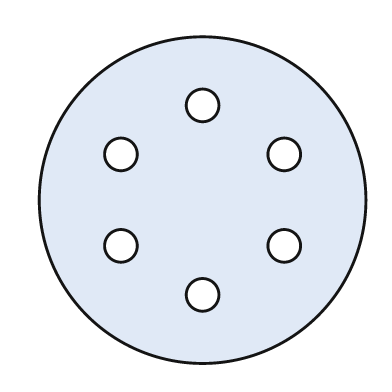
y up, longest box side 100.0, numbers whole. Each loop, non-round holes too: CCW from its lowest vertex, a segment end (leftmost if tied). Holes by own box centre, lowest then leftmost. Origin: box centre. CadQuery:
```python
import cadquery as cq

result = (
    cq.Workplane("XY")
    .moveTo(0.0, 0.0)
    .circle(50.0)
    .moveTo(0.0, -29.0)
    .circle(5.0)
    .moveTo(-25.0, -14.0)
    .circle(5.0)
    .moveTo(25.0, -14.0)
    .circle(5.0)
    .moveTo(-25.0, 14.0)
    .circle(5.0)
    .moveTo(25.0, 14.0)
    .circle(5.0)
    .moveTo(0.0, 29.0)
    .circle(5.0)
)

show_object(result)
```